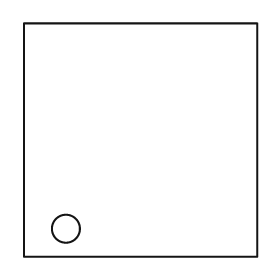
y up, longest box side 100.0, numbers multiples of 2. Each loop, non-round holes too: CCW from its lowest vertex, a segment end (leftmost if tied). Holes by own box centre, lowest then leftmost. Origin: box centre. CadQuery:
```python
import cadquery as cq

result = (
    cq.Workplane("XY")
    .moveTo(-50.0, -50.0)
    .lineTo(50.0, -50.0)
    .lineTo(50.0, 50.0)
    .lineTo(-50.0, 50.0)
    .close()
    .moveTo(-32.0, -38.0)
    .circle(6.0)
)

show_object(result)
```